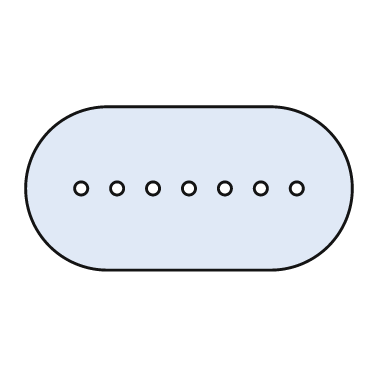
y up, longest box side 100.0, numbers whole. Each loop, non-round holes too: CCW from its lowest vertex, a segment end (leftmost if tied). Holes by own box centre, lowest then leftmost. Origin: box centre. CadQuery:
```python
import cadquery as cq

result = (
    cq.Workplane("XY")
    .moveTo(-25.0, -25.0)
    .lineTo(25.0, -25.0)
    .threePointArc((50.0, 0.0), (25.0, 25.0))
    .lineTo(-25.0, 25.0)
    .threePointArc((-50.0, 0.0), (-25.0, -25.0))
    .close()
    .moveTo(-33.0, 0.0)
    .circle(2.0)
    .moveTo(-22.0, 0.0)
    .circle(2.0)
    .moveTo(-11.0, 0.0)
    .circle(2.0)
    .moveTo(0.0, 0.0)
    .circle(2.0)
    .moveTo(11.0, 0.0)
    .circle(2.0)
    .moveTo(22.0, 0.0)
    .circle(2.0)
    .moveTo(33.0, 0.0)
    .circle(2.0)
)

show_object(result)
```